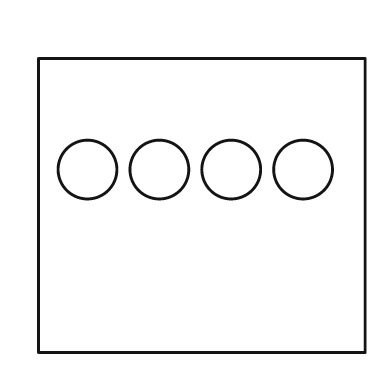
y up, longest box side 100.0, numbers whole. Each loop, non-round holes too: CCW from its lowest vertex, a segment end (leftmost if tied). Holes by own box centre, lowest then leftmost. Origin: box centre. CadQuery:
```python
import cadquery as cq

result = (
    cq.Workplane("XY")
    .moveTo(-50.0, -45.0)
    .lineTo(50.0, -45.0)
    .lineTo(50.0, 45.0)
    .lineTo(-50.0, 45.0)
    .close()
    .moveTo(-35.0, 11.0)
    .circle(9.0)
    .moveTo(-13.0, 11.0)
    .circle(9.0)
    .moveTo(9.0, 11.0)
    .circle(9.0)
    .moveTo(31.0, 11.0)
    .circle(9.0)
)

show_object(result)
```